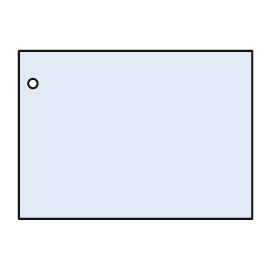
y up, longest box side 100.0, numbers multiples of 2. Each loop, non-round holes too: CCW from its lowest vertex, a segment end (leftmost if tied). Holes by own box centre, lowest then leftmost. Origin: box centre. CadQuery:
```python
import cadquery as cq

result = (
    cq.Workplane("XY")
    .moveTo(-50.0, -36.0)
    .lineTo(50.0, -36.0)
    .lineTo(50.0, 36.0)
    .lineTo(-50.0, 36.0)
    .close()
    .moveTo(-44.0, 22.0)
    .circle(2.0)
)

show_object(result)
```